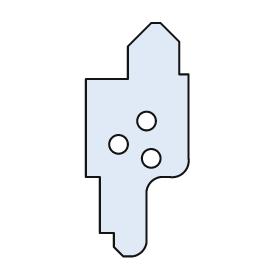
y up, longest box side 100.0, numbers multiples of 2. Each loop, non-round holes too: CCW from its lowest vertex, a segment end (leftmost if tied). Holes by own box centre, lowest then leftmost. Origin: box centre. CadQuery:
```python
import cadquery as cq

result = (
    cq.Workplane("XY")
    .moveTo(-6.0, -50.0)
    .lineTo(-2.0, -50.0)
    .threePointArc((2.0, -48.0), (4.0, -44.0))
    .lineTo(4.0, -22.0)
    .threePointArc((6.0, -18.0), (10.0, -16.0))
    .lineTo(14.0, -16.0)
    .threePointArc((20.0, -14.0), (22.0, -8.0))
    .lineTo(22.0, 28.0)
    .lineTo(18.0, 28.0)
    .lineTo(18.0, 42.0)
    .lineTo(10.0, 50.0)
    .lineTo(6.0, 50.0)
    .lineTo(-4.0, 40.0)
    .lineTo(-4.0, 26.0)
    .lineTo(-22.0, 26.0)
    .lineTo(-22.0, -16.0)
    .lineTo(-16.0, -16.0)
    .lineTo(-16.0, -40.0)
    .lineTo(-10.0, -40.0)
    .lineTo(-10.0, -46.0)
    .close()
    .moveTo(6.0, -8.0)
    .circle(4.0)
    .moveTo(-8.0, -2.0)
    .circle(4.0)
    .moveTo(4.0, 8.0)
    .circle(4.0)
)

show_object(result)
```